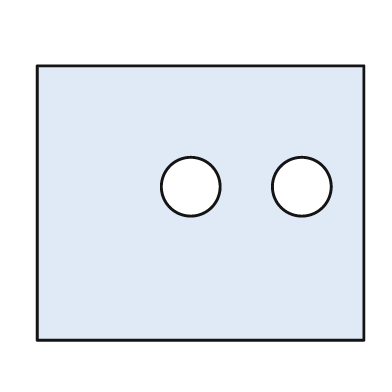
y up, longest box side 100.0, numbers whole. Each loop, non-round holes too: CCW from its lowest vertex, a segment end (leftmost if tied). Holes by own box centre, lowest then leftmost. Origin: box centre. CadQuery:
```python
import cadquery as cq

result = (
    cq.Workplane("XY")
    .moveTo(-50.0, -42.0)
    .lineTo(50.0, -42.0)
    .lineTo(50.0, 42.0)
    .lineTo(-50.0, 42.0)
    .close()
    .moveTo(-3.0, 5.0)
    .circle(9.0)
    .moveTo(31.0, 5.0)
    .circle(9.0)
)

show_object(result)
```